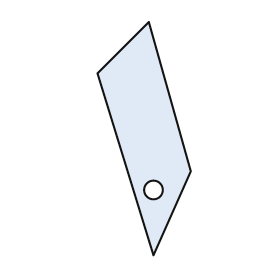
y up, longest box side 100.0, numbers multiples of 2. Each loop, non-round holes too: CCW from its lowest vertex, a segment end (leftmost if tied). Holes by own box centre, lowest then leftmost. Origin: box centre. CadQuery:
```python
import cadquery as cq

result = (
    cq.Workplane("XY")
    .moveTo(4.0, -50.0)
    .lineTo(20.0, -14.0)
    .lineTo(2.0, 50.0)
    .lineTo(-20.0, 28.0)
    .close()
    .moveTo(4.0, -22.0)
    .circle(4.0)
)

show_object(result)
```